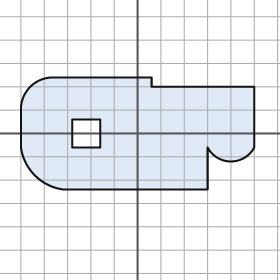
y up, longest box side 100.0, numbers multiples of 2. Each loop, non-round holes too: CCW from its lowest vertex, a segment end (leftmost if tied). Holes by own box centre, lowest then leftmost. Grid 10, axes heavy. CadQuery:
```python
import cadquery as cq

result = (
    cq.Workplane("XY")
    .moveTo(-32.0, -24.0)
    .lineTo(30.0, -24.0)
    .lineTo(30.0, -6.0)
    .threePointArc((40.0, -12.0), (50.0, -6.0))
    .lineTo(50.0, 20.0)
    .lineTo(6.0, 20.0)
    .lineTo(6.0, 24.0)
    .lineTo(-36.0, 24.0)
    .threePointArc((-46.0, 20.0), (-50.0, 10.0))
    .lineTo(-50.0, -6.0)
    .threePointArc((-44.0, -18.0), (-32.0, -24.0))
    .close()
    .moveTo(-28.0, -6.0)
    .lineTo(-16.0, -6.0)
    .lineTo(-16.0, 6.0)
    .lineTo(-28.0, 6.0)
    .close()
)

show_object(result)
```